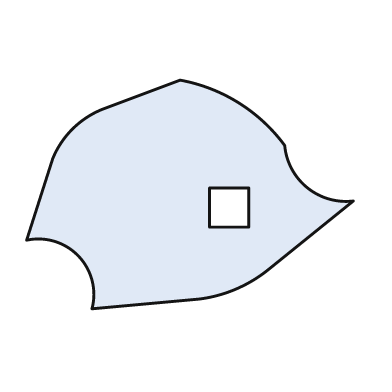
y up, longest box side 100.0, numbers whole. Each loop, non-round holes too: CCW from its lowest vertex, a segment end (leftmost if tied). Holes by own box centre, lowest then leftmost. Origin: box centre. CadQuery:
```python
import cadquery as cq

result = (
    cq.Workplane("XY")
    .moveTo(-30.0, -35.0)
    .lineTo(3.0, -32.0)
    .threePointArc((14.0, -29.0), (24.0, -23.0))
    .lineTo(50.0, -2.0)
    .threePointArc((36.0, 2.0), (29.0, 15.0))
    .threePointArc((15.0, 28.0), (-3.0, 35.0))
    .lineTo(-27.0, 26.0)
    .threePointArc((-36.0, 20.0), (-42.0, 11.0))
    .lineTo(-50.0, -14.0)
    .threePointArc((-34.0, -19.0), (-30.0, -35.0))
    .close()
    .moveTo(6.0, -10.0)
    .lineTo(18.0, -10.0)
    .lineTo(18.0, 2.0)
    .lineTo(6.0, 2.0)
    .close()
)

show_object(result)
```